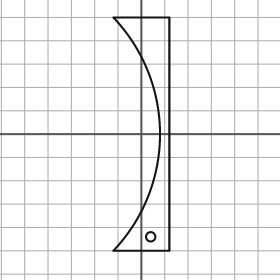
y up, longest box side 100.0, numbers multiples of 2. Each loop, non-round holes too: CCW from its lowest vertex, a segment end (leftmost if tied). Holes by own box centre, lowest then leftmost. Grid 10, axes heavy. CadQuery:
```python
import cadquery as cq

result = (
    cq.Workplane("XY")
    .moveTo(-12.0, -50.0)
    .lineTo(12.0, -50.0)
    .lineTo(12.0, 50.0)
    .lineTo(-12.0, 50.0)
    .threePointArc((8.0, 0.0), (-12.0, -50.0))
    .close()
    .moveTo(4.0, -44.0)
    .circle(2.0)
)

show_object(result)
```